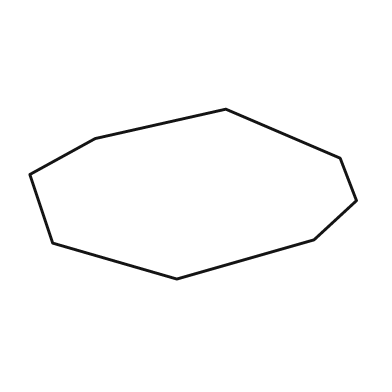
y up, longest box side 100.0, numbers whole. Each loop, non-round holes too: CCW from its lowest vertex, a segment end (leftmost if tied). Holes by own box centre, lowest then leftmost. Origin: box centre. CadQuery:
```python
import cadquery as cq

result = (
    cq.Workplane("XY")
    .moveTo(-5.0, -26.0)
    .lineTo(37.0, -14.0)
    .lineTo(50.0, -2.0)
    .lineTo(45.0, 11.0)
    .lineTo(10.0, 26.0)
    .lineTo(-30.0, 17.0)
    .lineTo(-50.0, 6.0)
    .lineTo(-43.0, -15.0)
    .close()
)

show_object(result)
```